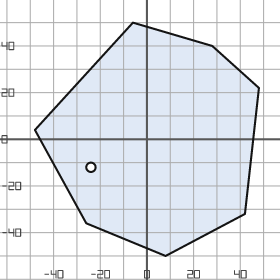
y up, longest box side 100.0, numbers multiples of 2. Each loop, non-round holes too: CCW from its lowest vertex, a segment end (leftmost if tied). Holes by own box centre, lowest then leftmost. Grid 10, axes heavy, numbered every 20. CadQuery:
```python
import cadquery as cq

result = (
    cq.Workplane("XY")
    .moveTo(8.0, -50.0)
    .lineTo(42.0, -32.0)
    .lineTo(48.0, 22.0)
    .lineTo(28.0, 40.0)
    .lineTo(-6.0, 50.0)
    .lineTo(-48.0, 4.0)
    .lineTo(-26.0, -36.0)
    .close()
    .moveTo(-24.0, -12.0)
    .circle(2.0)
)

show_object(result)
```